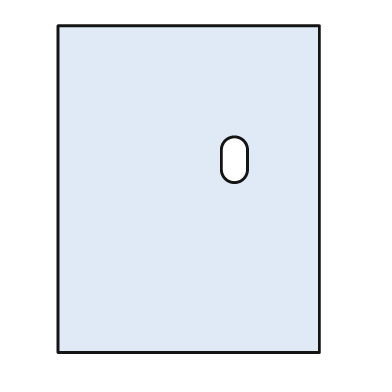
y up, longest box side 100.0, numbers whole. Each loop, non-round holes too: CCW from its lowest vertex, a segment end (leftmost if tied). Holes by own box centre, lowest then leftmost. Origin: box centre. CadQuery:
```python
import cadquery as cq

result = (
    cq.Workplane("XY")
    .moveTo(-40.0, -50.0)
    .lineTo(40.0, -50.0)
    .lineTo(40.0, 50.0)
    .lineTo(-40.0, 50.0)
    .close()
    .moveTo(10.0, 6.0)
    .threePointArc((14.0, 2.0), (18.0, 6.0))
    .lineTo(18.0, 12.0)
    .threePointArc((14.0, 16.0), (10.0, 12.0))
    .close()
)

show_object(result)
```